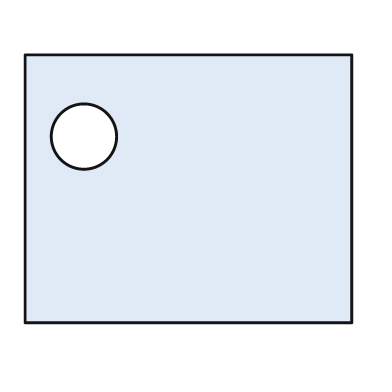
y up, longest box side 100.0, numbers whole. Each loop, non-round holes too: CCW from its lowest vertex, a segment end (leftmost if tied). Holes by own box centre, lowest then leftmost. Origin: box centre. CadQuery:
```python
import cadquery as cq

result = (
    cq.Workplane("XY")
    .moveTo(-50.0, -41.0)
    .lineTo(50.0, -41.0)
    .lineTo(50.0, 41.0)
    .lineTo(-50.0, 41.0)
    .close()
    .moveTo(-32.0, 16.0)
    .circle(10.0)
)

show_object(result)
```